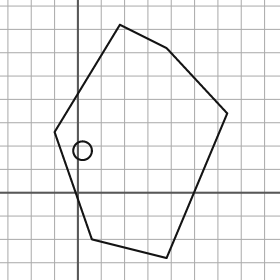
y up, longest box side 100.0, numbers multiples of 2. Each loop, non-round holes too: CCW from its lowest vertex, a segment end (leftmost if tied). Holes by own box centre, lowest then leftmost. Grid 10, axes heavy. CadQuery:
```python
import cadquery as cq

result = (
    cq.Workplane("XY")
    .moveTo(38.0, -28.0)
    .lineTo(64.0, 34.0)
    .lineTo(38.0, 62.0)
    .lineTo(18.0, 72.0)
    .lineTo(-10.0, 26.0)
    .lineTo(6.0, -20.0)
    .close()
    .moveTo(2.0, 18.0)
    .circle(4.0)
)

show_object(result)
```